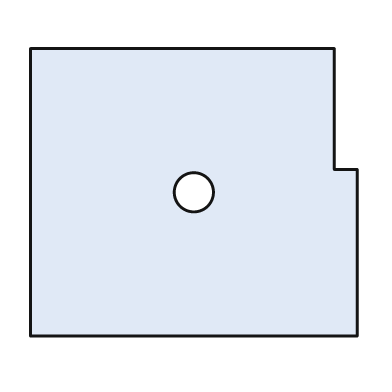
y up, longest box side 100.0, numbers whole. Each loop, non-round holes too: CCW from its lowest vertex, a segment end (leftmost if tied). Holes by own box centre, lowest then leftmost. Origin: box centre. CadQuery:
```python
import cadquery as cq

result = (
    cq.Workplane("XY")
    .moveTo(-50.0, -44.0)
    .lineTo(50.0, -44.0)
    .lineTo(50.0, 7.0)
    .lineTo(43.0, 7.0)
    .lineTo(43.0, 44.0)
    .lineTo(-50.0, 44.0)
    .close()
    .moveTo(0.0, 0.0)
    .circle(6.0)
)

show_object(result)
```